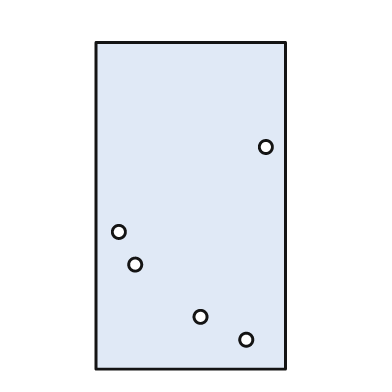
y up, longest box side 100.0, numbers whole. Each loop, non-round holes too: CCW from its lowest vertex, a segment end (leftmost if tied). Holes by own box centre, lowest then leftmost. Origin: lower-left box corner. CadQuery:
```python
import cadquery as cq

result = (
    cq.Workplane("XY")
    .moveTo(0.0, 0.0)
    .lineTo(58.0, 0.0)
    .lineTo(58.0, 100.0)
    .lineTo(0.0, 100.0)
    .close()
    .moveTo(46.0, 9.0)
    .circle(2.0)
    .moveTo(32.0, 16.0)
    .circle(2.0)
    .moveTo(12.0, 32.0)
    .circle(2.0)
    .moveTo(7.0, 42.0)
    .circle(2.0)
    .moveTo(52.0, 68.0)
    .circle(2.0)
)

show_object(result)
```